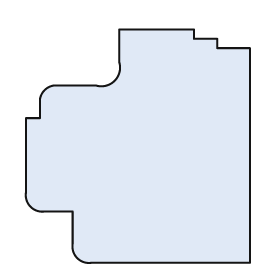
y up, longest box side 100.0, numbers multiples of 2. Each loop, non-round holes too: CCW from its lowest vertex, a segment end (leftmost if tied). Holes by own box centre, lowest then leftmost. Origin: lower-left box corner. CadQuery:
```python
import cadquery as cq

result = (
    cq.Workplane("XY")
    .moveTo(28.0, 0.0)
    .lineTo(96.0, 0.0)
    .lineTo(96.0, 92.0)
    .lineTo(82.0, 92.0)
    .lineTo(82.0, 96.0)
    .lineTo(72.0, 96.0)
    .lineTo(72.0, 100.0)
    .lineTo(40.0, 100.0)
    .lineTo(40.0, 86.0)
    .threePointArc((38.0, 78.0), (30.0, 76.0))
    .lineTo(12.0, 76.0)
    .threePointArc((8.0, 74.0), (6.0, 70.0))
    .lineTo(6.0, 62.0)
    .lineTo(0.0, 62.0)
    .lineTo(0.0, 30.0)
    .threePointArc((2.0, 24.0), (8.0, 22.0))
    .lineTo(20.0, 22.0)
    .lineTo(20.0, 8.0)
    .threePointArc((22.0, 2.0), (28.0, 0.0))
    .close()
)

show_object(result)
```